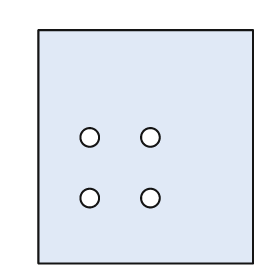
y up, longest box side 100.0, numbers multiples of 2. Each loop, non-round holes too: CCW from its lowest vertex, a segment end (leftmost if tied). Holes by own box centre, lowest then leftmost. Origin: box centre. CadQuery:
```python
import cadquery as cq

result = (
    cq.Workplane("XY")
    .moveTo(-46.0, -50.0)
    .lineTo(46.0, -50.0)
    .lineTo(46.0, 50.0)
    .lineTo(-46.0, 50.0)
    .close()
    .moveTo(-24.0, -22.0)
    .circle(4.0)
    .moveTo(2.0, -22.0)
    .circle(4.0)
    .moveTo(-24.0, 4.0)
    .circle(4.0)
    .moveTo(2.0, 4.0)
    .circle(4.0)
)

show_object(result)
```